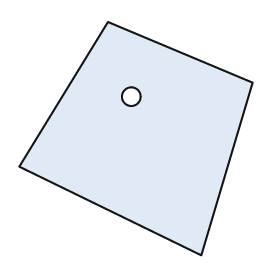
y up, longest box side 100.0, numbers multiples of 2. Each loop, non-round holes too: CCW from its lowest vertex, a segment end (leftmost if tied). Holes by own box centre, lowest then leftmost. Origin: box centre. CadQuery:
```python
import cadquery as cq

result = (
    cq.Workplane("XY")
    .moveTo(28.0, -50.0)
    .lineTo(50.0, 24.0)
    .lineTo(-12.0, 50.0)
    .lineTo(-50.0, -12.0)
    .close()
    .moveTo(-2.0, 18.0)
    .circle(4.0)
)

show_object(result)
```